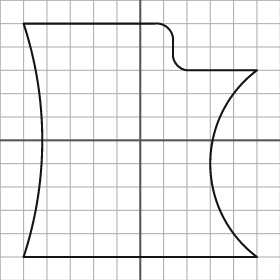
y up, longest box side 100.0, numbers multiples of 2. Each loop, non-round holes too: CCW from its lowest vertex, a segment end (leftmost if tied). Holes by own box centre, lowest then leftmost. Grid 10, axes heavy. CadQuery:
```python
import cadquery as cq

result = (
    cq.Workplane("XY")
    .moveTo(-50.0, -50.0)
    .lineTo(50.0, -50.0)
    .threePointArc((30.0, -10.0), (50.0, 30.0))
    .lineTo(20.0, 30.0)
    .threePointArc((16.0, 32.0), (14.0, 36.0))
    .lineTo(14.0, 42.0)
    .threePointArc((12.0, 48.0), (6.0, 50.0))
    .lineTo(-50.0, 50.0)
    .threePointArc((-42.0, 0.0), (-50.0, -50.0))
    .close()
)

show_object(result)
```